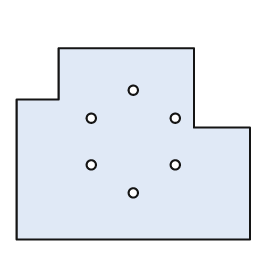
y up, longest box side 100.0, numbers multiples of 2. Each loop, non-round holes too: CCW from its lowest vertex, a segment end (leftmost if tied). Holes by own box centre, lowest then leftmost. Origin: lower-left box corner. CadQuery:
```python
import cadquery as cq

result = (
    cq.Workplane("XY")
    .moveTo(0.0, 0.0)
    .lineTo(100.0, 0.0)
    .lineTo(100.0, 48.0)
    .lineTo(76.0, 48.0)
    .lineTo(76.0, 82.0)
    .lineTo(18.0, 82.0)
    .lineTo(18.0, 60.0)
    .lineTo(0.0, 60.0)
    .close()
    .moveTo(50.0, 20.0)
    .circle(2.0)
    .moveTo(32.0, 32.0)
    .circle(2.0)
    .moveTo(68.0, 32.0)
    .circle(2.0)
    .moveTo(32.0, 52.0)
    .circle(2.0)
    .moveTo(68.0, 52.0)
    .circle(2.0)
    .moveTo(50.0, 64.0)
    .circle(2.0)
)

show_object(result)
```